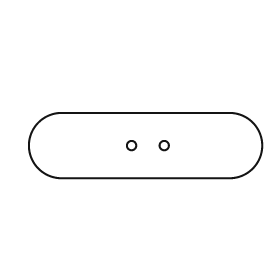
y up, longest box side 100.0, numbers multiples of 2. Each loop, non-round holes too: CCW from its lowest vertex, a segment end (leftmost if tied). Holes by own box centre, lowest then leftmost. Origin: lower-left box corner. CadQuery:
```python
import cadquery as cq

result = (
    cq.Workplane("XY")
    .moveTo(14.0, 0.0)
    .lineTo(86.0, 0.0)
    .threePointArc((100.0, 14.0), (86.0, 28.0))
    .lineTo(14.0, 28.0)
    .threePointArc((0.0, 14.0), (14.0, 0.0))
    .close()
    .moveTo(44.0, 14.0)
    .circle(2.0)
    .moveTo(58.0, 14.0)
    .circle(2.0)
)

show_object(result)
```